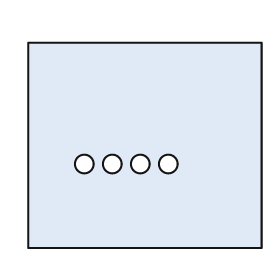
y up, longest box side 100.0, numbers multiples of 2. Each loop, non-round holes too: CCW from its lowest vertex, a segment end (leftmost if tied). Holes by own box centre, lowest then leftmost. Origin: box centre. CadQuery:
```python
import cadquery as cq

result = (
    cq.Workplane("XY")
    .moveTo(-50.0, -44.0)
    .lineTo(50.0, -44.0)
    .lineTo(50.0, 44.0)
    .lineTo(-50.0, 44.0)
    .close()
    .moveTo(-26.0, -8.0)
    .circle(4.0)
    .moveTo(-14.0, -8.0)
    .circle(4.0)
    .moveTo(-2.0, -8.0)
    .circle(4.0)
    .moveTo(10.0, -8.0)
    .circle(4.0)
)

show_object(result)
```